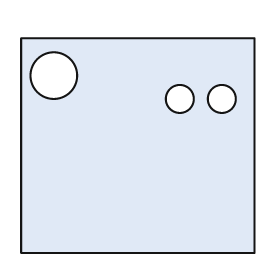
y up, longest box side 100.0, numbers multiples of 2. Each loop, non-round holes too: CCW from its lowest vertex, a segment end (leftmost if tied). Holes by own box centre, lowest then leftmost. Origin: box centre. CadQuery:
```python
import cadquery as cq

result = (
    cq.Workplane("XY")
    .moveTo(-50.0, -46.0)
    .lineTo(50.0, -46.0)
    .lineTo(50.0, 46.0)
    .lineTo(-50.0, 46.0)
    .close()
    .moveTo(18.0, 20.0)
    .circle(6.0)
    .moveTo(36.0, 20.0)
    .circle(6.0)
    .moveTo(-36.0, 30.0)
    .circle(10.0)
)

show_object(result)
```